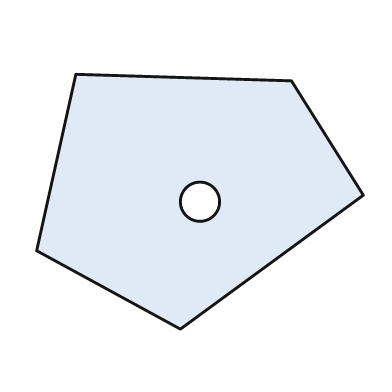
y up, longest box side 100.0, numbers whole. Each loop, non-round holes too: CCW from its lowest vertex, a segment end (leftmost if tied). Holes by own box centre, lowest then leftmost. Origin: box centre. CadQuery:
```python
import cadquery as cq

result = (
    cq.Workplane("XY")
    .moveTo(-6.0, -39.0)
    .lineTo(50.0, 2.0)
    .lineTo(28.0, 37.0)
    .lineTo(-38.0, 39.0)
    .lineTo(-50.0, -15.0)
    .close()
    .moveTo(0.0, 0.0)
    .circle(6.0)
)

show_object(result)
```